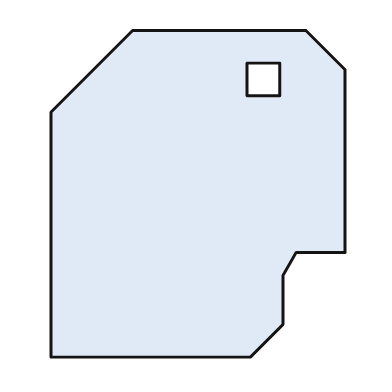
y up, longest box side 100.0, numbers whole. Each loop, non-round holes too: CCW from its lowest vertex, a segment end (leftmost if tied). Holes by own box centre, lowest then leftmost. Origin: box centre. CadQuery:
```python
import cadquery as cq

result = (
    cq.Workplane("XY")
    .moveTo(-45.0, -50.0)
    .lineTo(16.0, -50.0)
    .lineTo(26.0, -40.0)
    .lineTo(26.0, -25.0)
    .lineTo(30.0, -18.0)
    .lineTo(45.0, -18.0)
    .lineTo(45.0, 38.0)
    .lineTo(33.0, 50.0)
    .lineTo(-20.0, 50.0)
    .lineTo(-45.0, 25.0)
    .close()
    .moveTo(15.0, 30.0)
    .lineTo(25.0, 30.0)
    .lineTo(25.0, 40.0)
    .lineTo(15.0, 40.0)
    .close()
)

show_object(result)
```